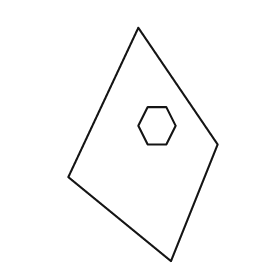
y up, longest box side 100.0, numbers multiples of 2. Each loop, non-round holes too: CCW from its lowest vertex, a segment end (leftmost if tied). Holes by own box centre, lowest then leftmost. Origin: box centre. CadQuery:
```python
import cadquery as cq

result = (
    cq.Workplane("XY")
    .moveTo(12.0, -50.0)
    .lineTo(32.0, 0.0)
    .lineTo(-2.0, 50.0)
    .lineTo(-32.0, -14.0)
    .close()
    .moveTo(2.0, 0.0)
    .lineTo(10.0, 0.0)
    .lineTo(14.0, 8.0)
    .lineTo(10.0, 16.0)
    .lineTo(2.0, 16.0)
    .lineTo(-2.0, 8.0)
    .close()
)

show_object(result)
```